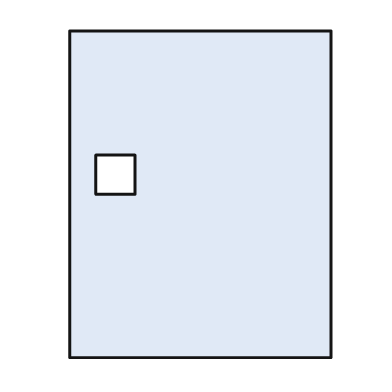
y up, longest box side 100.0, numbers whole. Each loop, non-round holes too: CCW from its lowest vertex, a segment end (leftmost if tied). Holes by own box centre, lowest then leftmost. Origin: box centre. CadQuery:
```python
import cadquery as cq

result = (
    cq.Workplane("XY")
    .moveTo(-40.0, -50.0)
    .lineTo(40.0, -50.0)
    .lineTo(40.0, 50.0)
    .lineTo(-40.0, 50.0)
    .close()
    .moveTo(-32.0, 0.0)
    .lineTo(-20.0, 0.0)
    .lineTo(-20.0, 12.0)
    .lineTo(-32.0, 12.0)
    .close()
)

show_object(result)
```